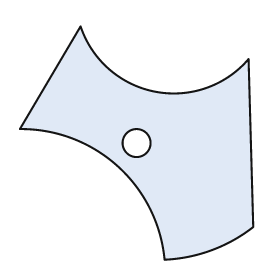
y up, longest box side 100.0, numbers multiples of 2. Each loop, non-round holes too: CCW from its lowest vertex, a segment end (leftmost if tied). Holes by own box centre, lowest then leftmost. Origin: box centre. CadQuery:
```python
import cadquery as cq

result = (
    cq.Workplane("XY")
    .moveTo(12.0, -50.0)
    .threePointArc((32.0, -46.0), (50.0, -36.0))
    .lineTo(48.0, 36.0)
    .threePointArc((8.0, 22.0), (-24.0, 50.0))
    .lineTo(-50.0, 6.0)
    .threePointArc((-8.0, -10.0), (12.0, -50.0))
    .close()
    .moveTo(0.0, 0.0)
    .circle(6.0)
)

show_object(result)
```